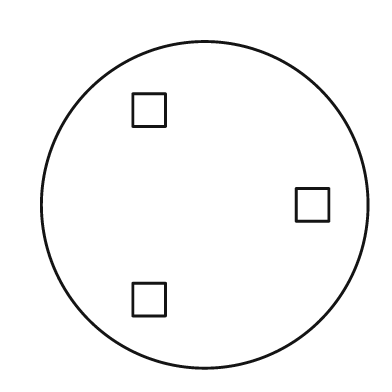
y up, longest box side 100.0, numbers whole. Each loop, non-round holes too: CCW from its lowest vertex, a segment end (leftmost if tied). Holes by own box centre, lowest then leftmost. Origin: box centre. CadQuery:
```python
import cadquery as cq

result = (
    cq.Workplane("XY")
    .moveTo(0.0, 0.0)
    .circle(50.0)
    .moveTo(-22.0, -34.0)
    .lineTo(-12.0, -34.0)
    .lineTo(-12.0, -24.0)
    .lineTo(-22.0, -24.0)
    .close()
    .moveTo(28.0, -5.0)
    .lineTo(38.0, -5.0)
    .lineTo(38.0, 5.0)
    .lineTo(28.0, 5.0)
    .close()
    .moveTo(-22.0, 24.0)
    .lineTo(-12.0, 24.0)
    .lineTo(-12.0, 34.0)
    .lineTo(-22.0, 34.0)
    .close()
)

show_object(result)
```